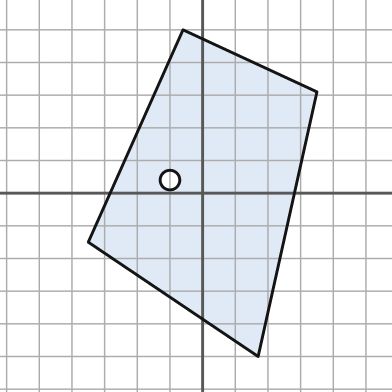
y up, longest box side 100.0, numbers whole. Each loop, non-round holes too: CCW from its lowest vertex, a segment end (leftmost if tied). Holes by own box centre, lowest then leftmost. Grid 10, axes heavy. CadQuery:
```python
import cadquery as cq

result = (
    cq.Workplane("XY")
    .moveTo(17.0, -50.0)
    .lineTo(35.0, 31.0)
    .lineTo(-6.0, 50.0)
    .lineTo(-35.0, -15.0)
    .close()
    .moveTo(-10.0, 4.0)
    .circle(3.0)
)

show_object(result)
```